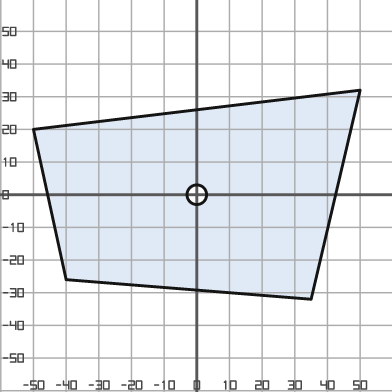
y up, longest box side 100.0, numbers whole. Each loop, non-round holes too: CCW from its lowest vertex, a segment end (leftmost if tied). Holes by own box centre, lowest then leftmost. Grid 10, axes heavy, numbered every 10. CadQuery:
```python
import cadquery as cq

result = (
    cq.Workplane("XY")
    .moveTo(35.0, -32.0)
    .lineTo(50.0, 32.0)
    .lineTo(-50.0, 20.0)
    .lineTo(-40.0, -26.0)
    .close()
    .moveTo(0.0, 0.0)
    .circle(3.0)
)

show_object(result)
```